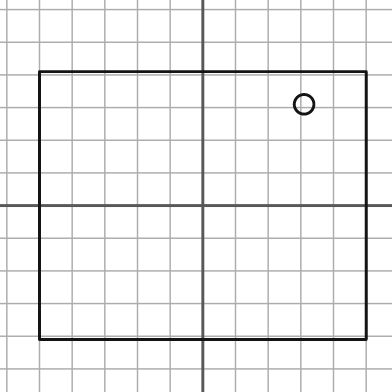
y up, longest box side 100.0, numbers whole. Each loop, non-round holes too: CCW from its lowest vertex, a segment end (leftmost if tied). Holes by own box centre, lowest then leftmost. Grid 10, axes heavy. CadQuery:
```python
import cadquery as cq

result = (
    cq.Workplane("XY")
    .moveTo(-50.0, -41.0)
    .lineTo(50.0, -41.0)
    .lineTo(50.0, 41.0)
    .lineTo(-50.0, 41.0)
    .close()
    .moveTo(31.0, 31.0)
    .circle(3.0)
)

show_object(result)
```